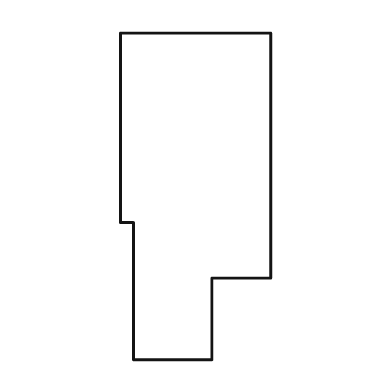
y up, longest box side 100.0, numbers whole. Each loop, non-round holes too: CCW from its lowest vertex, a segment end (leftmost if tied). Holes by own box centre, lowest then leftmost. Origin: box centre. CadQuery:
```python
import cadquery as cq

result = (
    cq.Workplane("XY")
    .moveTo(-19.0, -50.0)
    .lineTo(5.0, -50.0)
    .lineTo(5.0, -25.0)
    .lineTo(23.0, -25.0)
    .lineTo(23.0, 50.0)
    .lineTo(-23.0, 50.0)
    .lineTo(-23.0, -8.0)
    .lineTo(-19.0, -8.0)
    .close()
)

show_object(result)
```